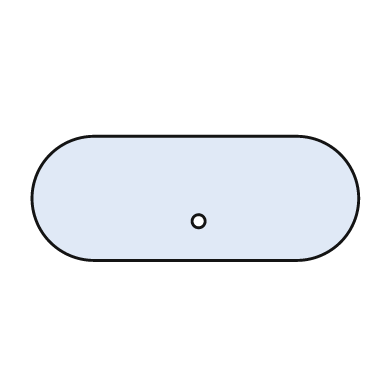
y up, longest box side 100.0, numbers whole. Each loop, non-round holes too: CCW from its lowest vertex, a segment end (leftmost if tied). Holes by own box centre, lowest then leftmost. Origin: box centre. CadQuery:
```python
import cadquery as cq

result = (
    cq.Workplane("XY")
    .moveTo(-31.0, -19.0)
    .lineTo(31.0, -19.0)
    .threePointArc((50.0, 0.0), (31.0, 19.0))
    .lineTo(-31.0, 19.0)
    .threePointArc((-50.0, 0.0), (-31.0, -19.0))
    .close()
    .moveTo(1.0, -7.0)
    .circle(2.0)
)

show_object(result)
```